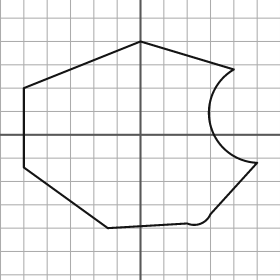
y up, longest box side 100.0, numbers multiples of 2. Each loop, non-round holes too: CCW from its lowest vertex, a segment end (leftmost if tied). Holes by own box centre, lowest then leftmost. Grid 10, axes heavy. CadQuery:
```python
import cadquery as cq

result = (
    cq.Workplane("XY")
    .moveTo(-14.0, -40.0)
    .lineTo(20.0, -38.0)
    .threePointArc((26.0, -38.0), (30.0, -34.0))
    .lineTo(50.0, -12.0)
    .threePointArc((30.0, 4.0), (40.0, 28.0))
    .lineTo(0.0, 40.0)
    .lineTo(-50.0, 20.0)
    .lineTo(-50.0, -14.0)
    .close()
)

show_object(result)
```